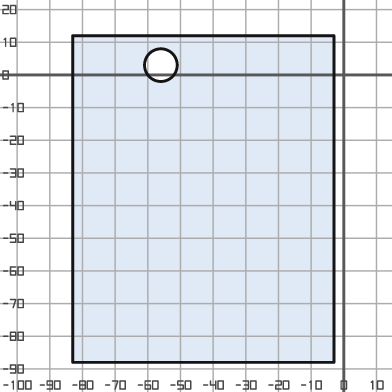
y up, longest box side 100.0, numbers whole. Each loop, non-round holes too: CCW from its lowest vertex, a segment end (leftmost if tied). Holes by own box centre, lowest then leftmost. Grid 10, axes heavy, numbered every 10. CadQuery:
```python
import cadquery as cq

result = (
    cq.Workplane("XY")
    .moveTo(-83.0, -88.0)
    .lineTo(-3.0, -88.0)
    .lineTo(-3.0, 12.0)
    .lineTo(-83.0, 12.0)
    .close()
    .moveTo(-56.0, 3.0)
    .circle(5.0)
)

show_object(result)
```